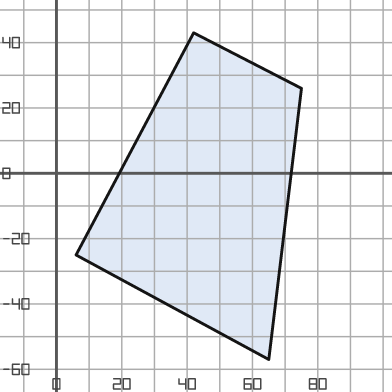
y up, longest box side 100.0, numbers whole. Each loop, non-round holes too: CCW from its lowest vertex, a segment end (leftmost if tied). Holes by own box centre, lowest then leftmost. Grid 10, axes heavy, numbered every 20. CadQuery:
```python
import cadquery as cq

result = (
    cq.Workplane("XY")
    .moveTo(65.0, -57.0)
    .lineTo(75.0, 26.0)
    .lineTo(42.0, 43.0)
    .lineTo(6.0, -25.0)
    .close()
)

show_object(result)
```